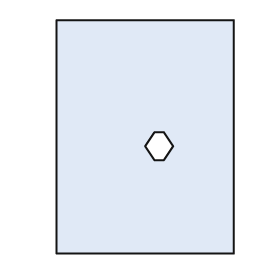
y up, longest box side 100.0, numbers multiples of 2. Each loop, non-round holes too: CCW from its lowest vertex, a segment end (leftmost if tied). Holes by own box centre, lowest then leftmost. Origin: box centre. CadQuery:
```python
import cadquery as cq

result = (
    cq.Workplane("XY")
    .moveTo(-38.0, -50.0)
    .lineTo(38.0, -50.0)
    .lineTo(38.0, 50.0)
    .lineTo(-38.0, 50.0)
    .close()
    .moveTo(4.0, -10.0)
    .lineTo(8.0, -10.0)
    .lineTo(12.0, -4.0)
    .lineTo(8.0, 2.0)
    .lineTo(4.0, 2.0)
    .lineTo(0.0, -4.0)
    .close()
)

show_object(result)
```